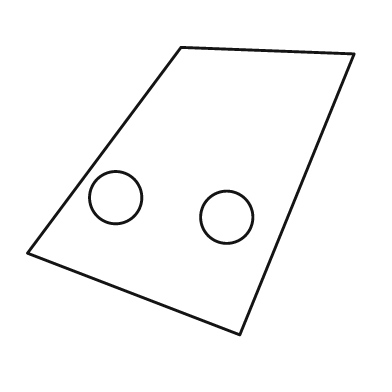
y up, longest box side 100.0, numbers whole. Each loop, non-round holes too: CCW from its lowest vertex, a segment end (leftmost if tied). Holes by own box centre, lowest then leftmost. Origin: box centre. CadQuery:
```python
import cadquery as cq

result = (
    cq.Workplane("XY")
    .moveTo(15.0, -44.0)
    .lineTo(50.0, 42.0)
    .lineTo(-3.0, 44.0)
    .lineTo(-50.0, -19.0)
    .close()
    .moveTo(11.0, -8.0)
    .circle(8.0)
    .moveTo(-23.0, -2.0)
    .circle(8.0)
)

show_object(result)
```